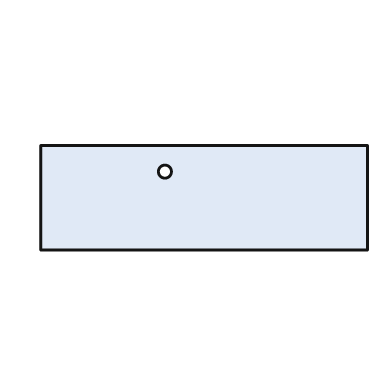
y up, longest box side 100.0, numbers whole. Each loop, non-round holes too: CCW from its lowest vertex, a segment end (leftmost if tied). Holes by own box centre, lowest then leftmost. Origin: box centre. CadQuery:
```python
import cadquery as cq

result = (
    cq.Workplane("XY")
    .moveTo(-50.0, -16.0)
    .lineTo(50.0, -16.0)
    .lineTo(50.0, 16.0)
    .lineTo(-50.0, 16.0)
    .close()
    .moveTo(-12.0, 8.0)
    .circle(2.0)
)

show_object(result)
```